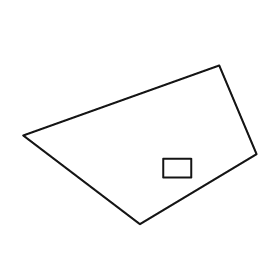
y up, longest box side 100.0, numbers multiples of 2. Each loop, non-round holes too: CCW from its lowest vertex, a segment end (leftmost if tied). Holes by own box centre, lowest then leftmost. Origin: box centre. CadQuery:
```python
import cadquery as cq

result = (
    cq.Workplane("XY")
    .moveTo(0.0, -34.0)
    .lineTo(50.0, -4.0)
    .lineTo(34.0, 34.0)
    .lineTo(-50.0, 4.0)
    .close()
    .moveTo(10.0, -14.0)
    .lineTo(22.0, -14.0)
    .lineTo(22.0, -6.0)
    .lineTo(10.0, -6.0)
    .close()
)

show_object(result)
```